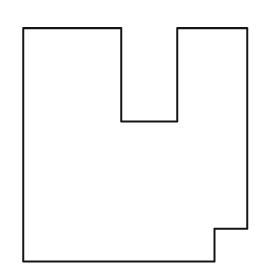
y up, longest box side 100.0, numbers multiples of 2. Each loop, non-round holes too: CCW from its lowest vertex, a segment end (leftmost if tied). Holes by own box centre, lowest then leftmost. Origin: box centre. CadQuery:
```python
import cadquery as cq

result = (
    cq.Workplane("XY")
    .moveTo(-48.0, -50.0)
    .lineTo(34.0, -50.0)
    .lineTo(34.0, -36.0)
    .lineTo(48.0, -36.0)
    .lineTo(48.0, 50.0)
    .lineTo(18.0, 50.0)
    .lineTo(18.0, 10.0)
    .lineTo(-6.0, 10.0)
    .lineTo(-6.0, 50.0)
    .lineTo(-48.0, 50.0)
    .close()
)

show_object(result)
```